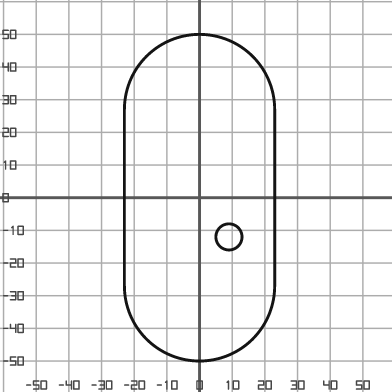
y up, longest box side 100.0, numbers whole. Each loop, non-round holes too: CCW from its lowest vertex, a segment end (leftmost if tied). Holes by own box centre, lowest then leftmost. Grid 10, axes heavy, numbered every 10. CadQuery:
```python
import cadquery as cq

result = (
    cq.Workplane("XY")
    .moveTo(-23.0, -27.0)
    .threePointArc((0.0, -50.0), (23.0, -27.0))
    .lineTo(23.0, 27.0)
    .threePointArc((0.0, 50.0), (-23.0, 27.0))
    .close()
    .moveTo(9.0, -12.0)
    .circle(4.0)
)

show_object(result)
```